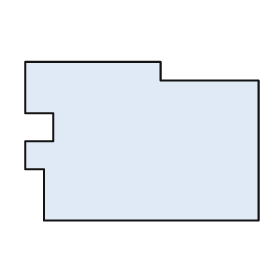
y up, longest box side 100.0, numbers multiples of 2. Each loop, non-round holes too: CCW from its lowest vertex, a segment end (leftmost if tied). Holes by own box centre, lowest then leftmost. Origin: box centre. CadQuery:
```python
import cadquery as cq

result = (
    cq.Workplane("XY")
    .moveTo(-42.0, -34.0)
    .lineTo(50.0, -34.0)
    .lineTo(50.0, 26.0)
    .lineTo(8.0, 26.0)
    .lineTo(8.0, 34.0)
    .lineTo(-50.0, 34.0)
    .lineTo(-50.0, 12.0)
    .lineTo(-38.0, 12.0)
    .lineTo(-38.0, 0.0)
    .lineTo(-50.0, 0.0)
    .lineTo(-50.0, -12.0)
    .lineTo(-42.0, -12.0)
    .close()
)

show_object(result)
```